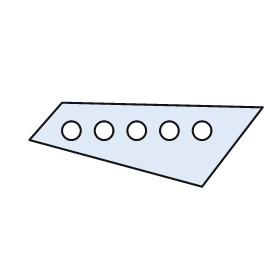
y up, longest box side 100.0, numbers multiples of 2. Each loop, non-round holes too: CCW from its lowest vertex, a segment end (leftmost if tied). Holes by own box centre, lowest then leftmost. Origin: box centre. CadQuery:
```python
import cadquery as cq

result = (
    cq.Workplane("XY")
    .moveTo(24.0, -18.0)
    .lineTo(50.0, 16.0)
    .lineTo(-36.0, 18.0)
    .lineTo(-50.0, 2.0)
    .close()
    .moveTo(-32.0, 6.0)
    .circle(4.0)
    .moveTo(-18.0, 6.0)
    .circle(4.0)
    .moveTo(-4.0, 6.0)
    .circle(4.0)
    .moveTo(10.0, 6.0)
    .circle(4.0)
    .moveTo(24.0, 6.0)
    .circle(4.0)
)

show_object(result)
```